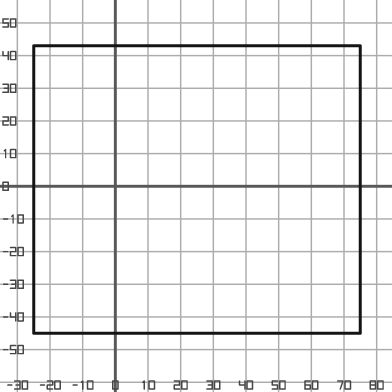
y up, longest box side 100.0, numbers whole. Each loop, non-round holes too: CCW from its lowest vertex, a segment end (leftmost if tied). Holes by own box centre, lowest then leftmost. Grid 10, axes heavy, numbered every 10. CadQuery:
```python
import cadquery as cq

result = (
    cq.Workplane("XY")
    .moveTo(-25.0, -45.0)
    .lineTo(75.0, -45.0)
    .lineTo(75.0, 43.0)
    .lineTo(-25.0, 43.0)
    .close()
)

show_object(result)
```